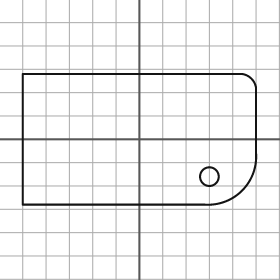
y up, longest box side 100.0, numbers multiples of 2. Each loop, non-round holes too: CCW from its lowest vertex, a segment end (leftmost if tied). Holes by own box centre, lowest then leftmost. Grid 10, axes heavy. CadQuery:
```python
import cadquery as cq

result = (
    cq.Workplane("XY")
    .moveTo(-50.0, -28.0)
    .lineTo(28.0, -28.0)
    .threePointArc((44.0, -22.0), (50.0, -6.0))
    .lineTo(50.0, 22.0)
    .threePointArc((48.0, 26.0), (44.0, 28.0))
    .lineTo(-50.0, 28.0)
    .close()
    .moveTo(30.0, -16.0)
    .circle(4.0)
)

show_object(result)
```